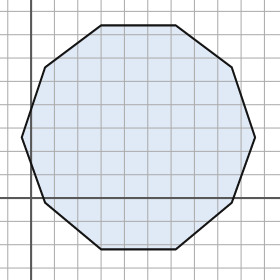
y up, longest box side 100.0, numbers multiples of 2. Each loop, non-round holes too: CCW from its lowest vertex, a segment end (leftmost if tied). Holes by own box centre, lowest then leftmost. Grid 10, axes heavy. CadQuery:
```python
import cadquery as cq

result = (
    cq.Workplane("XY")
    .moveTo(30.0, -22.0)
    .lineTo(62.0, -22.0)
    .lineTo(86.0, -2.0)
    .lineTo(96.0, 26.0)
    .lineTo(86.0, 56.0)
    .lineTo(62.0, 74.0)
    .lineTo(30.0, 74.0)
    .lineTo(6.0, 56.0)
    .lineTo(-4.0, 26.0)
    .lineTo(6.0, -2.0)
    .close()
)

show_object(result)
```